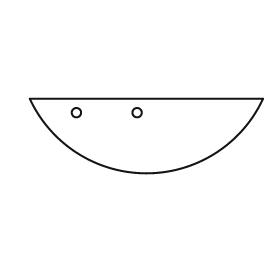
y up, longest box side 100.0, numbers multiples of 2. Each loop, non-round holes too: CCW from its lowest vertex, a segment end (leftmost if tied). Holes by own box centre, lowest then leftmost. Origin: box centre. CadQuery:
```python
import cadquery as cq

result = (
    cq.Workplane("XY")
    .moveTo(-50.0, 16.0)
    .threePointArc((0.0, -16.0), (50.0, 16.0))
    .close()
    .moveTo(-30.0, 10.0)
    .circle(2.0)
    .moveTo(-4.0, 10.0)
    .circle(2.0)
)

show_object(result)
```